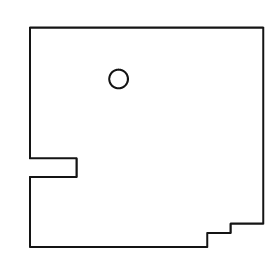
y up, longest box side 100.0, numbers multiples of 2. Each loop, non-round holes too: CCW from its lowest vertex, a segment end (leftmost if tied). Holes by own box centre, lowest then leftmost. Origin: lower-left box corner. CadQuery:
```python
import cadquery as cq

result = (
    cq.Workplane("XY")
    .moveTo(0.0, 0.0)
    .lineTo(76.0, 0.0)
    .lineTo(76.0, 6.0)
    .lineTo(86.0, 6.0)
    .lineTo(86.0, 10.0)
    .lineTo(100.0, 10.0)
    .lineTo(100.0, 94.0)
    .lineTo(0.0, 94.0)
    .lineTo(0.0, 38.0)
    .lineTo(20.0, 38.0)
    .lineTo(20.0, 30.0)
    .lineTo(0.0, 30.0)
    .close()
    .moveTo(38.0, 72.0)
    .circle(4.0)
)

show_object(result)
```